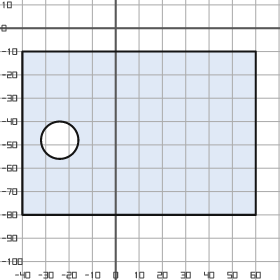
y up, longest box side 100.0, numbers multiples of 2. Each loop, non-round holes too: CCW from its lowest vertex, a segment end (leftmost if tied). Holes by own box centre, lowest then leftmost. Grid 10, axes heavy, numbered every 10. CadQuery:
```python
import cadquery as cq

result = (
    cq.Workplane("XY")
    .moveTo(-40.0, -80.0)
    .lineTo(60.0, -80.0)
    .lineTo(60.0, -10.0)
    .lineTo(-40.0, -10.0)
    .close()
    .moveTo(-24.0, -48.0)
    .circle(8.0)
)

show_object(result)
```